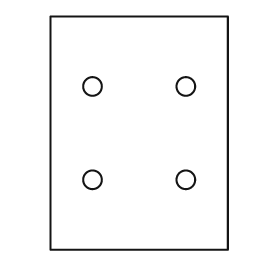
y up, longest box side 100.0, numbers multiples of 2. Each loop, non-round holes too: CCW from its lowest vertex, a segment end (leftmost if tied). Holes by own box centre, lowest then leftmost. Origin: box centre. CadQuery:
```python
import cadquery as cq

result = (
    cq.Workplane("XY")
    .moveTo(-38.0, -50.0)
    .lineTo(38.0, -50.0)
    .lineTo(38.0, 50.0)
    .lineTo(-38.0, 50.0)
    .close()
    .moveTo(-20.0, -20.0)
    .circle(4.0)
    .moveTo(20.0, -20.0)
    .circle(4.0)
    .moveTo(-20.0, 20.0)
    .circle(4.0)
    .moveTo(20.0, 20.0)
    .circle(4.0)
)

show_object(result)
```